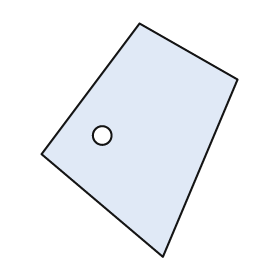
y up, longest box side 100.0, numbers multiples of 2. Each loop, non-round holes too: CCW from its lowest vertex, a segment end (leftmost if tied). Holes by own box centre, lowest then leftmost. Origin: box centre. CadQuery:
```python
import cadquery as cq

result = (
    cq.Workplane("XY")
    .moveTo(10.0, -50.0)
    .lineTo(42.0, 26.0)
    .lineTo(0.0, 50.0)
    .lineTo(-42.0, -6.0)
    .close()
    .moveTo(-16.0, 2.0)
    .circle(4.0)
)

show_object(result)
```